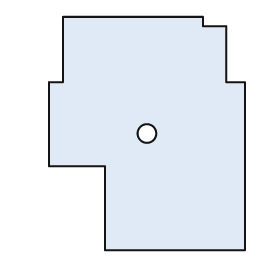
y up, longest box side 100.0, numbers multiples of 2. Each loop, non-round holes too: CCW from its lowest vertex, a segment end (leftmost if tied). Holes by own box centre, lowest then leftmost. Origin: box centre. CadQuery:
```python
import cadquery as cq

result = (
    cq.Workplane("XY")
    .moveTo(-18.0, -50.0)
    .lineTo(42.0, -50.0)
    .lineTo(42.0, 22.0)
    .lineTo(34.0, 22.0)
    .lineTo(34.0, 46.0)
    .lineTo(24.0, 46.0)
    .lineTo(24.0, 50.0)
    .lineTo(-36.0, 50.0)
    .lineTo(-36.0, 22.0)
    .lineTo(-42.0, 22.0)
    .lineTo(-42.0, -14.0)
    .lineTo(-18.0, -14.0)
    .close()
    .moveTo(0.0, 0.0)
    .circle(4.0)
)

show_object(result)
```